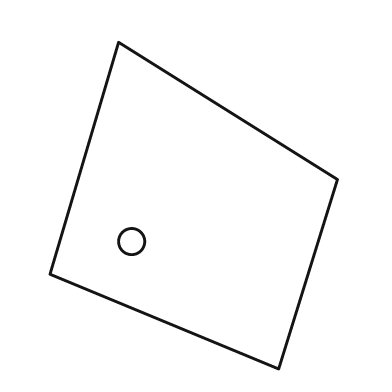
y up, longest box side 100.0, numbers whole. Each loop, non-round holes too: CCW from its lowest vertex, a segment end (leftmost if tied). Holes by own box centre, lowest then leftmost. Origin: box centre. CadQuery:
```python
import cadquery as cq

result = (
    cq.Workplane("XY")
    .moveTo(26.0, -50.0)
    .lineTo(44.0, 8.0)
    .lineTo(-23.0, 50.0)
    .lineTo(-44.0, -21.0)
    .close()
    .moveTo(-19.0, -11.0)
    .circle(4.0)
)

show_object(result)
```